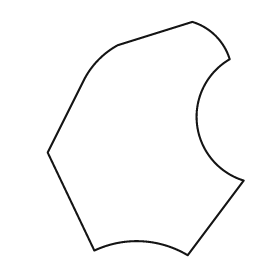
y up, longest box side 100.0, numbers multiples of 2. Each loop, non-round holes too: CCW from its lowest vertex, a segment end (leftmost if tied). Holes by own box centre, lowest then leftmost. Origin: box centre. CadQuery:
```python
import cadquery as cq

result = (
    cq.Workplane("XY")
    .moveTo(18.0, -50.0)
    .lineTo(42.0, -18.0)
    .threePointArc((22.0, 6.0), (36.0, 34.0))
    .threePointArc((30.0, 44.0), (20.0, 50.0))
    .lineTo(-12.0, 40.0)
    .threePointArc((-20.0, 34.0), (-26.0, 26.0))
    .lineTo(-42.0, -6.0)
    .lineTo(-22.0, -48.0)
    .threePointArc((-2.0, -44.0), (18.0, -50.0))
    .close()
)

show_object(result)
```